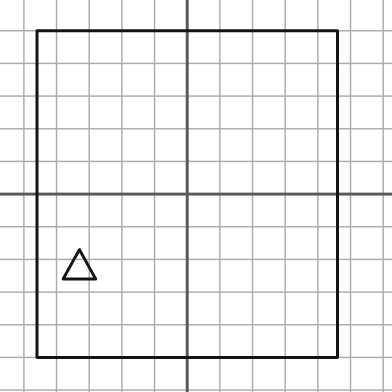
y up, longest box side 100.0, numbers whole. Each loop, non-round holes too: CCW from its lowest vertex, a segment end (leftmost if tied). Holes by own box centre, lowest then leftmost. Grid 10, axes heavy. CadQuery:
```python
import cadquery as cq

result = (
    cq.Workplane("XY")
    .moveTo(-46.0, -50.0)
    .lineTo(46.0, -50.0)
    .lineTo(46.0, 50.0)
    .lineTo(-46.0, 50.0)
    .close()
    .moveTo(-38.0, -26.0)
    .lineTo(-28.0, -26.0)
    .lineTo(-33.0, -17.0)
    .close()
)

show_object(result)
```